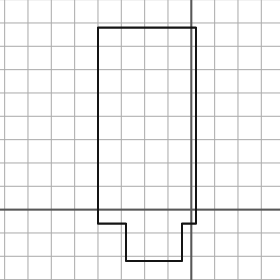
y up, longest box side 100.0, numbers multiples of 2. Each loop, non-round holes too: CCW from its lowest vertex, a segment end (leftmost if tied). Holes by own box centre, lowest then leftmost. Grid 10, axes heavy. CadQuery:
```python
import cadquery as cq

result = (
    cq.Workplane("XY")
    .moveTo(-28.0, -22.0)
    .lineTo(-4.0, -22.0)
    .lineTo(-4.0, -6.0)
    .lineTo(2.0, -6.0)
    .lineTo(2.0, 78.0)
    .lineTo(-40.0, 78.0)
    .lineTo(-40.0, -6.0)
    .lineTo(-28.0, -6.0)
    .close()
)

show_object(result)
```